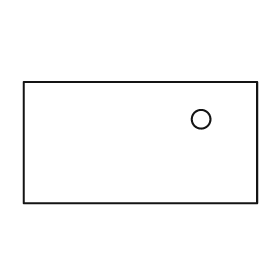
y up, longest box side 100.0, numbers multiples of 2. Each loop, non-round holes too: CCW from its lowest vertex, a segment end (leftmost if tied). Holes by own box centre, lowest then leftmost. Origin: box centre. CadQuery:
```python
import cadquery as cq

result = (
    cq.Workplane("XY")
    .moveTo(-50.0, -26.0)
    .lineTo(50.0, -26.0)
    .lineTo(50.0, 26.0)
    .lineTo(-50.0, 26.0)
    .close()
    .moveTo(26.0, 10.0)
    .circle(4.0)
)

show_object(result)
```